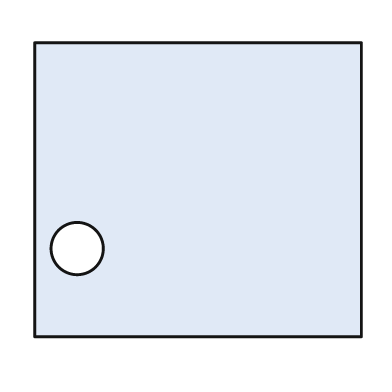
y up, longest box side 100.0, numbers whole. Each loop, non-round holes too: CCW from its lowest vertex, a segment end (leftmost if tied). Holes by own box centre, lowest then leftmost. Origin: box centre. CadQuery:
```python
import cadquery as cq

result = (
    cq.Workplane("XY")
    .moveTo(-50.0, -45.0)
    .lineTo(50.0, -45.0)
    .lineTo(50.0, 45.0)
    .lineTo(-50.0, 45.0)
    .close()
    .moveTo(-37.0, -18.0)
    .circle(8.0)
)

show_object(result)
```